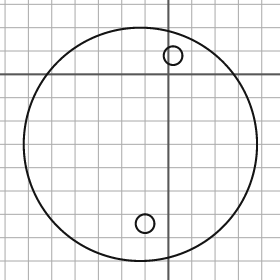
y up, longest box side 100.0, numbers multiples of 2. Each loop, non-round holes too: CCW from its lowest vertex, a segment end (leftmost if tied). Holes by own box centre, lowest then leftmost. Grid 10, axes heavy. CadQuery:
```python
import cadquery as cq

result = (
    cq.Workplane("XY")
    .moveTo(-12.0, -30.0)
    .circle(50.0)
    .moveTo(-10.0, -64.0)
    .circle(4.0)
    .moveTo(2.0, 8.0)
    .circle(4.0)
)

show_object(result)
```